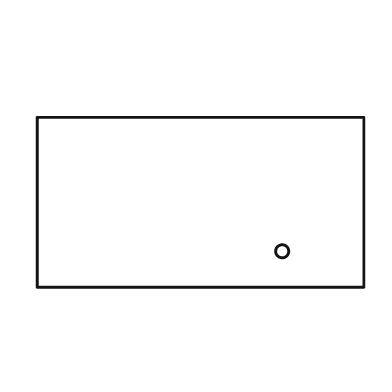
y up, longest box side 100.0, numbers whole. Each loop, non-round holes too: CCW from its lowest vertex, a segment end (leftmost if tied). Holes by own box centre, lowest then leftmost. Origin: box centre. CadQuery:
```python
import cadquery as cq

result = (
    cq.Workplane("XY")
    .moveTo(-50.0, -26.0)
    .lineTo(50.0, -26.0)
    .lineTo(50.0, 26.0)
    .lineTo(-50.0, 26.0)
    .close()
    .moveTo(25.0, -15.0)
    .circle(2.0)
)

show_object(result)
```